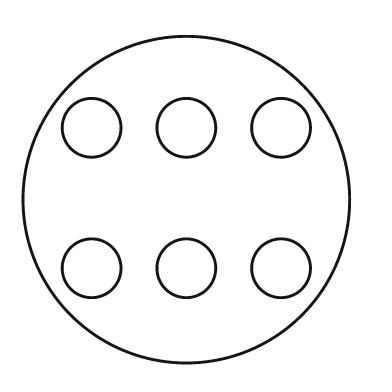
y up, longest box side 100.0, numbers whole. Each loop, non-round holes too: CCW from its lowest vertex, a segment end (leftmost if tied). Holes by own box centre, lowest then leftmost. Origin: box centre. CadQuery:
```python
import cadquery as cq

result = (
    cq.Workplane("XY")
    .moveTo(0.0, 0.0)
    .circle(50.0)
    .moveTo(-29.0, -21.0)
    .circle(9.0)
    .moveTo(0.0, -21.0)
    .circle(9.0)
    .moveTo(29.0, -21.0)
    .circle(9.0)
    .moveTo(-29.0, 22.0)
    .circle(9.0)
    .moveTo(0.0, 22.0)
    .circle(9.0)
    .moveTo(29.0, 22.0)
    .circle(9.0)
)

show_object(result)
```